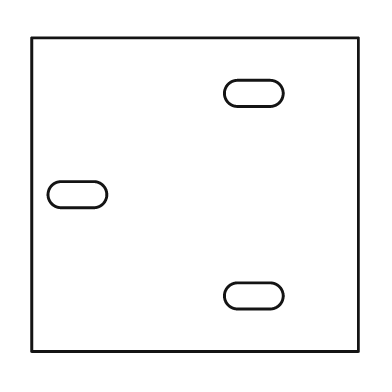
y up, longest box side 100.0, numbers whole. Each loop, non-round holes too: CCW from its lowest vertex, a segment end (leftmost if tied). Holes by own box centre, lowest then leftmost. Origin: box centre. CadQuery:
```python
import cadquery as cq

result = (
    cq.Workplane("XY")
    .moveTo(-50.0, -48.0)
    .lineTo(50.0, -48.0)
    .lineTo(50.0, 48.0)
    .lineTo(-50.0, 48.0)
    .close()
    .moveTo(13.0, -35.0)
    .lineTo(23.0, -35.0)
    .threePointArc((27.0, -31.0), (23.0, -27.0))
    .lineTo(13.0, -27.0)
    .threePointArc((9.0, -31.0), (13.0, -35.0))
    .close()
    .moveTo(-41.0, -4.0)
    .lineTo(-31.0, -4.0)
    .threePointArc((-27.0, 0.0), (-31.0, 4.0))
    .lineTo(-41.0, 4.0)
    .threePointArc((-45.0, 0.0), (-41.0, -4.0))
    .close()
    .moveTo(13.0, 27.0)
    .lineTo(23.0, 27.0)
    .threePointArc((27.0, 31.0), (23.0, 35.0))
    .lineTo(13.0, 35.0)
    .threePointArc((9.0, 31.0), (13.0, 27.0))
    .close()
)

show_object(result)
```